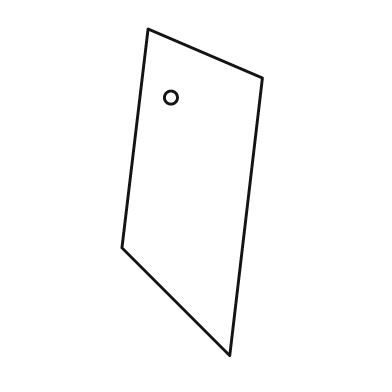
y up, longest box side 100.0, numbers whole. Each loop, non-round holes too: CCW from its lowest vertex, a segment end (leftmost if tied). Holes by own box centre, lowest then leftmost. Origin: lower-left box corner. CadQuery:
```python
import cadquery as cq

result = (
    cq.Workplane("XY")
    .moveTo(33.0, 0.0)
    .lineTo(43.0, 85.0)
    .lineTo(8.0, 100.0)
    .lineTo(0.0, 33.0)
    .close()
    .moveTo(15.0, 79.0)
    .circle(2.0)
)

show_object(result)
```